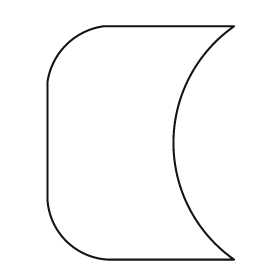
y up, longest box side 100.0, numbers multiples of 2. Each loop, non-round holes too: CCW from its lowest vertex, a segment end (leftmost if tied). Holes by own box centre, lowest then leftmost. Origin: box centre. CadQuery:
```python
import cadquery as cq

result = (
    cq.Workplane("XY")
    .moveTo(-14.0, -50.0)
    .lineTo(40.0, -50.0)
    .threePointArc((14.0, 0.0), (40.0, 50.0))
    .lineTo(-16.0, 50.0)
    .threePointArc((-32.0, 42.0), (-40.0, 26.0))
    .lineTo(-40.0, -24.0)
    .threePointArc((-32.0, -42.0), (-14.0, -50.0))
    .close()
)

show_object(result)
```